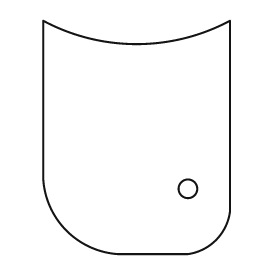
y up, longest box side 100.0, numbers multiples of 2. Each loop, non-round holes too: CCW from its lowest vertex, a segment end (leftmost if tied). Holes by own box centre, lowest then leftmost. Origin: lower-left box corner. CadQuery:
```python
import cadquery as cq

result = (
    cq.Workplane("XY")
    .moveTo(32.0, 0.0)
    .lineTo(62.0, 0.0)
    .threePointArc((74.0, 6.0), (80.0, 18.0))
    .lineTo(80.0, 100.0)
    .threePointArc((40.0, 90.0), (0.0, 100.0))
    .lineTo(0.0, 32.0)
    .threePointArc((10.0, 10.0), (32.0, 0.0))
    .close()
    .moveTo(62.0, 28.0)
    .circle(4.0)
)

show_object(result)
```